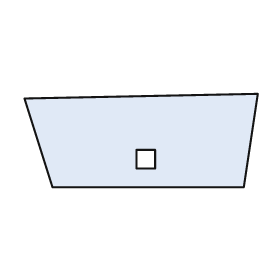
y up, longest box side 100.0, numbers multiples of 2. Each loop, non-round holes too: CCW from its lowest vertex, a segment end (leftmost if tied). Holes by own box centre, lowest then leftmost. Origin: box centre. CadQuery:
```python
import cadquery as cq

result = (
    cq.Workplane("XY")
    .moveTo(-38.0, -20.0)
    .lineTo(44.0, -20.0)
    .lineTo(50.0, 20.0)
    .lineTo(-50.0, 18.0)
    .close()
    .moveTo(-2.0, -12.0)
    .lineTo(6.0, -12.0)
    .lineTo(6.0, -4.0)
    .lineTo(-2.0, -4.0)
    .close()
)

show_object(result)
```